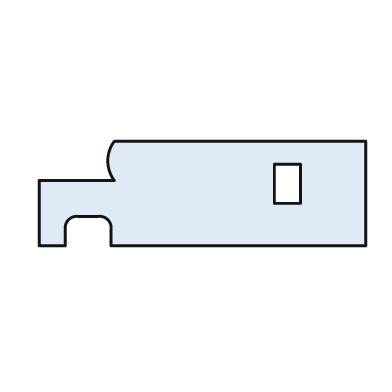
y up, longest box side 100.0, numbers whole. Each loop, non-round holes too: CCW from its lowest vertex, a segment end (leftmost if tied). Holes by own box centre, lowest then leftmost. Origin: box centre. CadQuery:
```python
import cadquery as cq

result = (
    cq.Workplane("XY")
    .moveTo(-50.0, -16.0)
    .lineTo(-42.0, -16.0)
    .lineTo(-42.0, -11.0)
    .threePointArc((-41.0, -8.0), (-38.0, -7.0))
    .lineTo(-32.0, -7.0)
    .threePointArc((-29.0, -8.0), (-28.0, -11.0))
    .lineTo(-28.0, -16.0)
    .lineTo(50.0, -16.0)
    .lineTo(50.0, 16.0)
    .lineTo(-27.0, 16.0)
    .threePointArc((-29.0, 10.0), (-27.0, 4.0))
    .lineTo(-50.0, 4.0)
    .close()
    .moveTo(22.0, -3.0)
    .lineTo(30.0, -3.0)
    .lineTo(30.0, 9.0)
    .lineTo(22.0, 9.0)
    .close()
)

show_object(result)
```